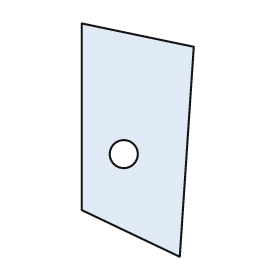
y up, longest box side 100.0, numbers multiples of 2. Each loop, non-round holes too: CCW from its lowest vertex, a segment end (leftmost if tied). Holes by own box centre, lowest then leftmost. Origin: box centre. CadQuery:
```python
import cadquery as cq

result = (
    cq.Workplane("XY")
    .moveTo(18.0, -50.0)
    .lineTo(24.0, 40.0)
    .lineTo(-24.0, 50.0)
    .lineTo(-24.0, -30.0)
    .close()
    .moveTo(-6.0, -6.0)
    .circle(6.0)
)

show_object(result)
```